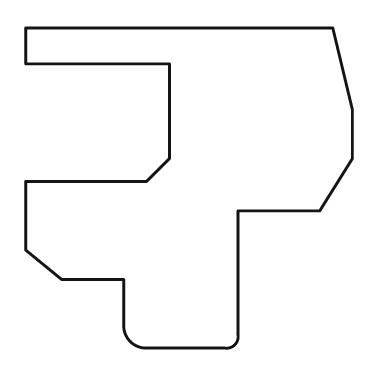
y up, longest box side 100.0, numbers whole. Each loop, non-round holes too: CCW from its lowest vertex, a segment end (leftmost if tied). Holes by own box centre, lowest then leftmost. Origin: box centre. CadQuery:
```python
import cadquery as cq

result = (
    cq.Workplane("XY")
    .moveTo(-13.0, -49.0)
    .lineTo(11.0, -49.0)
    .threePointArc((14.0, -48.0), (15.0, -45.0))
    .lineTo(15.0, -7.0)
    .lineTo(40.0, -7.0)
    .lineTo(50.0, 9.0)
    .lineTo(50.0, 24.0)
    .lineTo(44.0, 49.0)
    .lineTo(-50.0, 49.0)
    .lineTo(-50.0, 38.0)
    .lineTo(-6.0, 38.0)
    .lineTo(-6.0, 9.0)
    .lineTo(-13.0, 2.0)
    .lineTo(-50.0, 2.0)
    .lineTo(-50.0, -19.0)
    .lineTo(-39.0, -28.0)
    .lineTo(-20.0, -28.0)
    .lineTo(-20.0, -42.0)
    .threePointArc((-18.0, -47.0), (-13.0, -49.0))
    .close()
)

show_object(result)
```